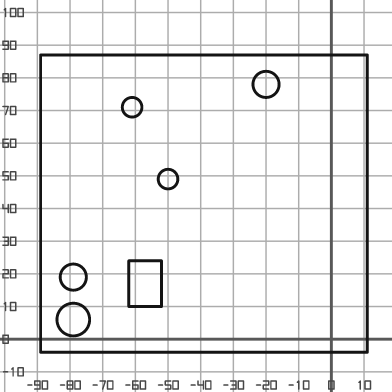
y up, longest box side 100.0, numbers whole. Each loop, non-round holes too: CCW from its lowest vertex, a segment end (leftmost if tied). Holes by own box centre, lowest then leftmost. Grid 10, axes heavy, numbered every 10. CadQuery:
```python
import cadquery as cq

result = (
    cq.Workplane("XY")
    .moveTo(-89.0, -4.0)
    .lineTo(11.0, -4.0)
    .lineTo(11.0, 87.0)
    .lineTo(-89.0, 87.0)
    .close()
    .moveTo(-79.0, 6.0)
    .circle(5.0)
    .moveTo(-62.0, 10.0)
    .lineTo(-52.0, 10.0)
    .lineTo(-52.0, 24.0)
    .lineTo(-62.0, 24.0)
    .close()
    .moveTo(-79.0, 19.0)
    .circle(4.0)
    .moveTo(-50.0, 49.0)
    .circle(3.0)
    .moveTo(-61.0, 71.0)
    .circle(3.0)
    .moveTo(-20.0, 78.0)
    .circle(4.0)
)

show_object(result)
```